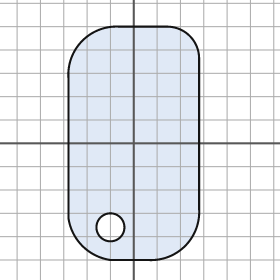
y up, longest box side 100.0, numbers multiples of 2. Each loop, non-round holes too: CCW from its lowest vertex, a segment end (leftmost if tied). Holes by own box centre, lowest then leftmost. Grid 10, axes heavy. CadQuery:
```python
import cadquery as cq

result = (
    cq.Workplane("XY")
    .moveTo(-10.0, -50.0)
    .lineTo(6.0, -50.0)
    .threePointArc((22.0, -44.0), (28.0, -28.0))
    .lineTo(28.0, 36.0)
    .threePointArc((24.0, 46.0), (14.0, 50.0))
    .lineTo(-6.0, 50.0)
    .threePointArc((-22.0, 44.0), (-28.0, 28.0))
    .lineTo(-28.0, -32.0)
    .threePointArc((-22.0, -44.0), (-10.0, -50.0))
    .close()
    .moveTo(-10.0, -36.0)
    .circle(6.0)
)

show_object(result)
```